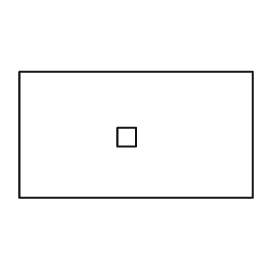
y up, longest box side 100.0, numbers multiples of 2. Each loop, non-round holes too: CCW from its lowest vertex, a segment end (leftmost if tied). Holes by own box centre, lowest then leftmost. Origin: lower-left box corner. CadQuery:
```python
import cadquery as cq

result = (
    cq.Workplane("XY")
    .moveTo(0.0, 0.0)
    .lineTo(100.0, 0.0)
    .lineTo(100.0, 54.0)
    .lineTo(0.0, 54.0)
    .close()
    .moveTo(42.0, 22.0)
    .lineTo(50.0, 22.0)
    .lineTo(50.0, 30.0)
    .lineTo(42.0, 30.0)
    .close()
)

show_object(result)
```